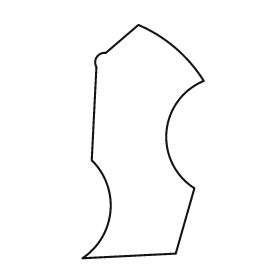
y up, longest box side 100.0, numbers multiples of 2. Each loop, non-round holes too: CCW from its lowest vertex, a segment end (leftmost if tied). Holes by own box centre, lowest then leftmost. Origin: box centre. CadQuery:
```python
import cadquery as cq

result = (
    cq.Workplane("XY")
    .moveTo(-26.0, -50.0)
    .lineTo(14.0, -48.0)
    .lineTo(22.0, -20.0)
    .threePointArc((10.0, 4.0), (26.0, 26.0))
    .threePointArc((14.0, 40.0), (-2.0, 50.0))
    .lineTo(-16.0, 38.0)
    .threePointArc((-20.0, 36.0), (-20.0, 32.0))
    .lineTo(-22.0, -8.0)
    .threePointArc((-14.0, -30.0), (-26.0, -50.0))
    .close()
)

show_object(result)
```